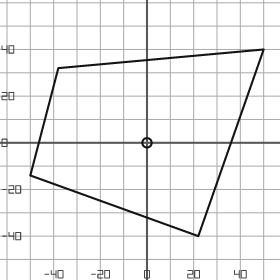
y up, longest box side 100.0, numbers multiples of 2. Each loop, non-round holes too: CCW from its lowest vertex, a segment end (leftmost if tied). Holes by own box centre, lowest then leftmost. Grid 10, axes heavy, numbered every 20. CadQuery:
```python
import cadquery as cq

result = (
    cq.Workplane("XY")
    .moveTo(22.0, -40.0)
    .lineTo(50.0, 40.0)
    .lineTo(-38.0, 32.0)
    .lineTo(-50.0, -14.0)
    .close()
    .moveTo(0.0, 0.0)
    .circle(2.0)
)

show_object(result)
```